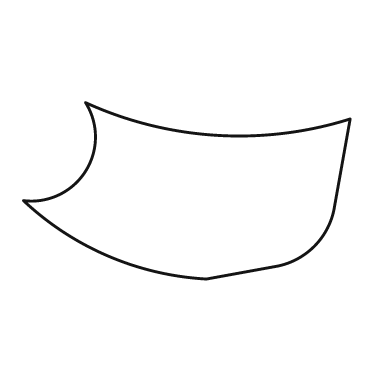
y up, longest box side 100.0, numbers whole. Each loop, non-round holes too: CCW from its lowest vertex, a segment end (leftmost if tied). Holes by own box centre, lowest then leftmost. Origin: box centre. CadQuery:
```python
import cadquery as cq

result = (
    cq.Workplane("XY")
    .moveTo(6.0, -27.0)
    .lineTo(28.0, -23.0)
    .threePointArc((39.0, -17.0), (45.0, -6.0))
    .lineTo(50.0, 22.0)
    .threePointArc((9.0, 17.0), (-31.0, 27.0))
    .threePointArc((-31.0, 6.0), (-50.0, -3.0))
    .threePointArc((-24.0, -20.0), (6.0, -27.0))
    .close()
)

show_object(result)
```